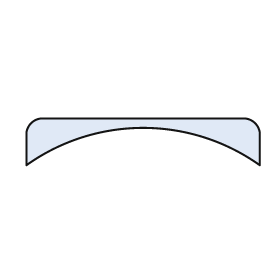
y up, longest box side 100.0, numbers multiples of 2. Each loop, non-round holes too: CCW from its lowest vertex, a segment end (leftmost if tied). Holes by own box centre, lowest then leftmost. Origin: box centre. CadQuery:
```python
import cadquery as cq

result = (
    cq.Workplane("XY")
    .moveTo(-50.0, -10.0)
    .threePointArc((0.0, 6.0), (50.0, -10.0))
    .lineTo(50.0, 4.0)
    .threePointArc((48.0, 8.0), (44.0, 10.0))
    .lineTo(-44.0, 10.0)
    .threePointArc((-48.0, 8.0), (-50.0, 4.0))
    .close()
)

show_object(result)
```